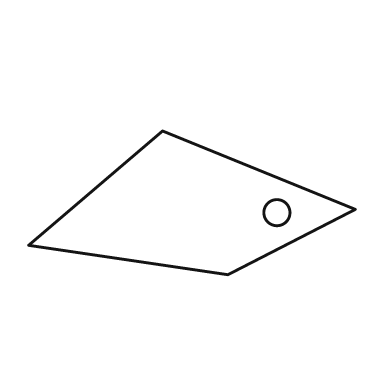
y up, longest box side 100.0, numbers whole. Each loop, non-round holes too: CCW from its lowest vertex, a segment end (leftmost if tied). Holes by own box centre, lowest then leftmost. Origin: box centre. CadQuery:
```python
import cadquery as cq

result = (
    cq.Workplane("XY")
    .moveTo(11.0, -22.0)
    .lineTo(50.0, -2.0)
    .lineTo(-9.0, 22.0)
    .lineTo(-50.0, -13.0)
    .close()
    .moveTo(26.0, -3.0)
    .circle(4.0)
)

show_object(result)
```